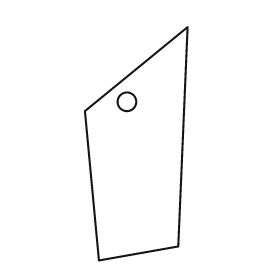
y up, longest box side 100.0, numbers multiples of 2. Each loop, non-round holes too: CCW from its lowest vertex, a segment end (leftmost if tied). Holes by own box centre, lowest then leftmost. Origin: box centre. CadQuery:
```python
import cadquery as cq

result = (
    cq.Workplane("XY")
    .moveTo(-16.0, -50.0)
    .lineTo(18.0, -44.0)
    .lineTo(22.0, 50.0)
    .lineTo(-22.0, 14.0)
    .close()
    .moveTo(-4.0, 18.0)
    .circle(4.0)
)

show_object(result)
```